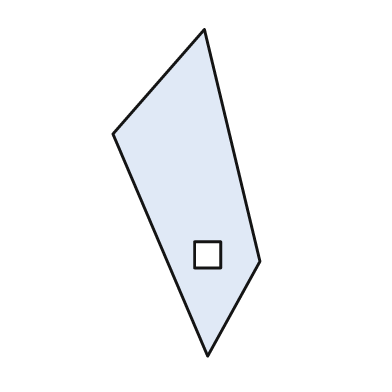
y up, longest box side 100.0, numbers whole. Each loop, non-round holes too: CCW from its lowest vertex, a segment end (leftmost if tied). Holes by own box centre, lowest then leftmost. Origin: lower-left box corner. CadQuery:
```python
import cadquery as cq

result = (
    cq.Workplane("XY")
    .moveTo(29.0, 0.0)
    .lineTo(45.0, 29.0)
    .lineTo(28.0, 100.0)
    .lineTo(0.0, 68.0)
    .close()
    .moveTo(25.0, 27.0)
    .lineTo(33.0, 27.0)
    .lineTo(33.0, 35.0)
    .lineTo(25.0, 35.0)
    .close()
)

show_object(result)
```